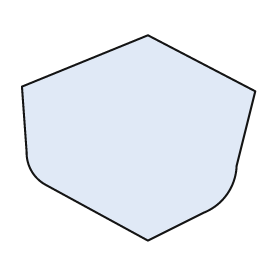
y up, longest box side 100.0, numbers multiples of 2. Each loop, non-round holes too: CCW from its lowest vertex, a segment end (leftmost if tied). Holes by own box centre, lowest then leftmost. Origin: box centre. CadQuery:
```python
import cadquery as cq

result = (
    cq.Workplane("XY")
    .moveTo(4.0, -44.0)
    .lineTo(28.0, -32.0)
    .threePointArc((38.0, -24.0), (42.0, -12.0))
    .lineTo(50.0, 20.0)
    .lineTo(4.0, 44.0)
    .lineTo(-50.0, 22.0)
    .lineTo(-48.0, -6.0)
    .threePointArc((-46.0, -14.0), (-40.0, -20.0))
    .close()
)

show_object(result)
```